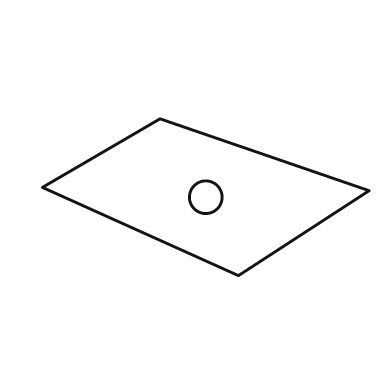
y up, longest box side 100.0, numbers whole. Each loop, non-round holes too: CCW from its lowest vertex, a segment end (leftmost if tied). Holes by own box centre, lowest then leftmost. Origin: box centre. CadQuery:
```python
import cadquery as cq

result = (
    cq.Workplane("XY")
    .moveTo(10.0, -24.0)
    .lineTo(50.0, 2.0)
    .lineTo(-14.0, 24.0)
    .lineTo(-50.0, 3.0)
    .close()
    .moveTo(0.0, 0.0)
    .circle(5.0)
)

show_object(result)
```